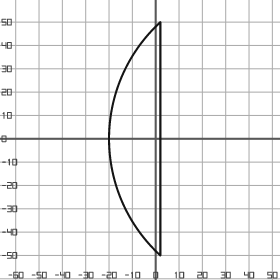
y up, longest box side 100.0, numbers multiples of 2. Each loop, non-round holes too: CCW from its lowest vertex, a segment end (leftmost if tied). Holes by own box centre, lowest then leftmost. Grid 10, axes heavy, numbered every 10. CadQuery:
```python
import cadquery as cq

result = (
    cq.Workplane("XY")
    .moveTo(2.0, -50.0)
    .lineTo(2.0, 50.0)
    .threePointArc((-20.0, 0.0), (2.0, -50.0))
    .close()
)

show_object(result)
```